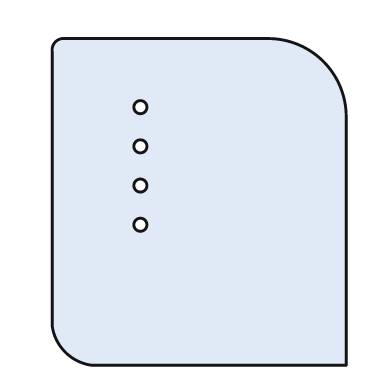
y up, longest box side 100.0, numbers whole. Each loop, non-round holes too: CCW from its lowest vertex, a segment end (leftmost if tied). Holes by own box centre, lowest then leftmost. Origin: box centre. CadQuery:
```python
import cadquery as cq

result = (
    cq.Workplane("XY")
    .moveTo(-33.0, -50.0)
    .lineTo(45.0, -50.0)
    .lineTo(45.0, 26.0)
    .threePointArc((38.0, 43.0), (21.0, 50.0))
    .lineTo(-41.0, 50.0)
    .threePointArc((-44.0, 49.0), (-45.0, 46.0))
    .lineTo(-45.0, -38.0)
    .threePointArc((-41.0, -46.0), (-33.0, -50.0))
    .close()
    .moveTo(-18.0, -7.0)
    .circle(2.0)
    .moveTo(-18.0, 5.0)
    .circle(2.0)
    .moveTo(-18.0, 17.0)
    .circle(2.0)
    .moveTo(-18.0, 29.0)
    .circle(2.0)
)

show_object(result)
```